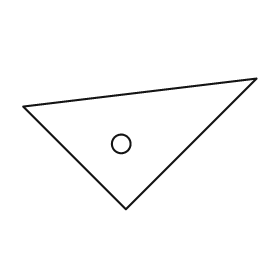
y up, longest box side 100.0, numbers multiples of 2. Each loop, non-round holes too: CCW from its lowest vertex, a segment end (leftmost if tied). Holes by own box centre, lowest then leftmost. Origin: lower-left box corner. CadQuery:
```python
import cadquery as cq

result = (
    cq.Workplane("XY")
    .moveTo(44.0, 0.0)
    .lineTo(100.0, 56.0)
    .lineTo(0.0, 44.0)
    .close()
    .moveTo(42.0, 28.0)
    .circle(4.0)
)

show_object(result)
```